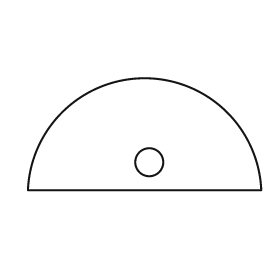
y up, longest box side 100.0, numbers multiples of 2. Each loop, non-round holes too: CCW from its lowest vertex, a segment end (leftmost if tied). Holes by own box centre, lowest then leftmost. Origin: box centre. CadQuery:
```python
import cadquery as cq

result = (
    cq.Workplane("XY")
    .moveTo(-50.0, -24.0)
    .lineTo(50.0, -24.0)
    .threePointArc((0.0, 24.0), (-50.0, -24.0))
    .close()
    .moveTo(2.0, -12.0)
    .circle(6.0)
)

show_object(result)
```